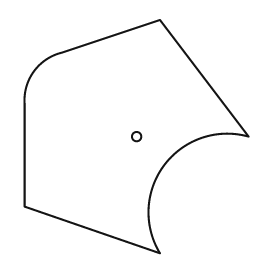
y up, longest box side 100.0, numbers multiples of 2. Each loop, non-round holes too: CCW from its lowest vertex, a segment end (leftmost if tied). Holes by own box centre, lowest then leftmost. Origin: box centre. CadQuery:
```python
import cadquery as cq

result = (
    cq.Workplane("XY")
    .moveTo(10.0, -50.0)
    .threePointArc((12.0, -12.0), (48.0, 0.0))
    .lineTo(10.0, 50.0)
    .lineTo(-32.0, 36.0)
    .threePointArc((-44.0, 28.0), (-48.0, 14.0))
    .lineTo(-48.0, -30.0)
    .close()
    .moveTo(0.0, 0.0)
    .circle(2.0)
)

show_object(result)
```